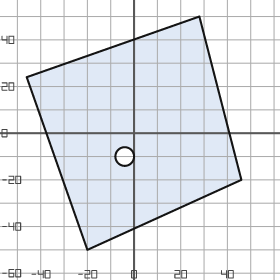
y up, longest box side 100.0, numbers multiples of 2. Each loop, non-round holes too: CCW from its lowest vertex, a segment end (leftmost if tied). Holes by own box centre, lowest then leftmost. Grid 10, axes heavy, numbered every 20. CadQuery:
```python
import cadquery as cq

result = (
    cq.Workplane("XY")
    .moveTo(-20.0, -50.0)
    .lineTo(46.0, -20.0)
    .lineTo(28.0, 50.0)
    .lineTo(-46.0, 24.0)
    .close()
    .moveTo(-4.0, -10.0)
    .circle(4.0)
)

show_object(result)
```